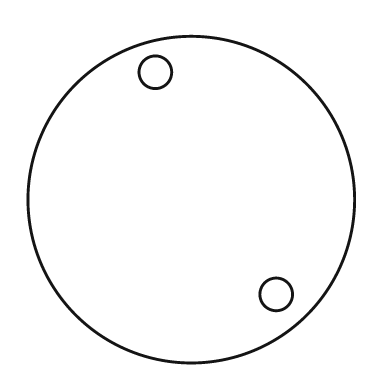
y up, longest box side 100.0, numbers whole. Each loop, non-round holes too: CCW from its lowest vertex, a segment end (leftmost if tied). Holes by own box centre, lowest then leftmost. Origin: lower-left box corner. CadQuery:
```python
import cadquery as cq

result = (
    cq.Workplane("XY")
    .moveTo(50.0, 50.0)
    .circle(50.0)
    .moveTo(76.0, 21.0)
    .circle(5.0)
    .moveTo(39.0, 89.0)
    .circle(5.0)
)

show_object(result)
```